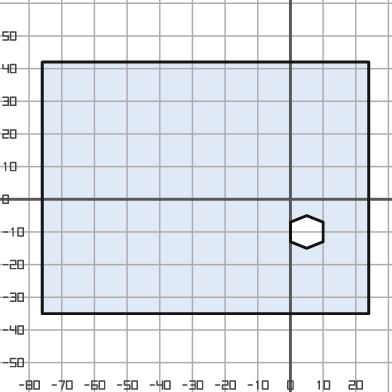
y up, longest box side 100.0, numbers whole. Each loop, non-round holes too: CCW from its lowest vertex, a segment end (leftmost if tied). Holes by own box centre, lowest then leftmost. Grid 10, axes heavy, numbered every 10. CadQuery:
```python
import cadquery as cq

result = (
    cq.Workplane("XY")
    .moveTo(-76.0, -35.0)
    .lineTo(24.0, -35.0)
    .lineTo(24.0, 42.0)
    .lineTo(-76.0, 42.0)
    .close()
    .moveTo(5.0, -15.0)
    .lineTo(10.0, -13.0)
    .lineTo(10.0, -7.0)
    .lineTo(5.0, -5.0)
    .lineTo(0.0, -7.0)
    .lineTo(0.0, -13.0)
    .close()
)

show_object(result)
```